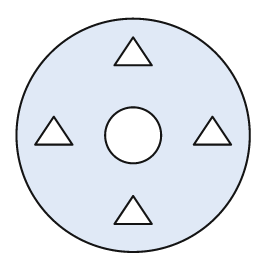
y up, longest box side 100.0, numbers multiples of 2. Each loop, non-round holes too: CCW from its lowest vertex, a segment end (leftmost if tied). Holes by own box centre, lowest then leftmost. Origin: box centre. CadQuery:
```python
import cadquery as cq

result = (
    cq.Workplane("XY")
    .moveTo(0.0, 0.0)
    .circle(50.0)
    .moveTo(-8.0, -38.0)
    .lineTo(8.0, -38.0)
    .lineTo(0.0, -26.0)
    .close()
    .moveTo(0.0, 0.0)
    .circle(12.0)
    .moveTo(-42.0, -4.0)
    .lineTo(-26.0, -4.0)
    .lineTo(-34.0, 8.0)
    .close()
    .moveTo(26.0, -4.0)
    .lineTo(42.0, -4.0)
    .lineTo(34.0, 8.0)
    .close()
    .moveTo(-8.0, 30.0)
    .lineTo(8.0, 30.0)
    .lineTo(0.0, 42.0)
    .close()
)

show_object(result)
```